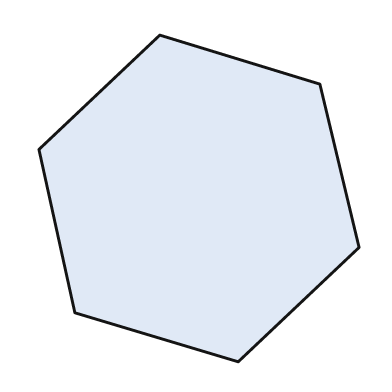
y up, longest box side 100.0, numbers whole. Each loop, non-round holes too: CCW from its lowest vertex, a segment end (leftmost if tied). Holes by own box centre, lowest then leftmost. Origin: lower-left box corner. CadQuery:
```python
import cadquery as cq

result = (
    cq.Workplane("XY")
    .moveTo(61.0, 0.0)
    .lineTo(98.0, 35.0)
    .lineTo(86.0, 85.0)
    .lineTo(37.0, 100.0)
    .lineTo(0.0, 65.0)
    .lineTo(11.0, 15.0)
    .close()
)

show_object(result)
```